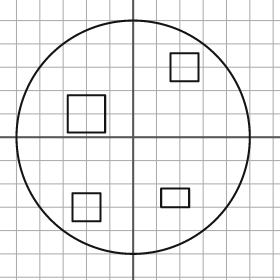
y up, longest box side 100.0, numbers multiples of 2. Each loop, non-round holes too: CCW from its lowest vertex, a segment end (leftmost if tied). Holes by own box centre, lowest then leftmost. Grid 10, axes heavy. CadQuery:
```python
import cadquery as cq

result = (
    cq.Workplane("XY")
    .moveTo(0.0, 0.0)
    .circle(50.0)
    .moveTo(-26.0, -36.0)
    .lineTo(-14.0, -36.0)
    .lineTo(-14.0, -24.0)
    .lineTo(-26.0, -24.0)
    .close()
    .moveTo(12.0, -30.0)
    .lineTo(24.0, -30.0)
    .lineTo(24.0, -22.0)
    .lineTo(12.0, -22.0)
    .close()
    .moveTo(-28.0, 2.0)
    .lineTo(-12.0, 2.0)
    .lineTo(-12.0, 18.0)
    .lineTo(-28.0, 18.0)
    .close()
    .moveTo(16.0, 24.0)
    .lineTo(28.0, 24.0)
    .lineTo(28.0, 36.0)
    .lineTo(16.0, 36.0)
    .close()
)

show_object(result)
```